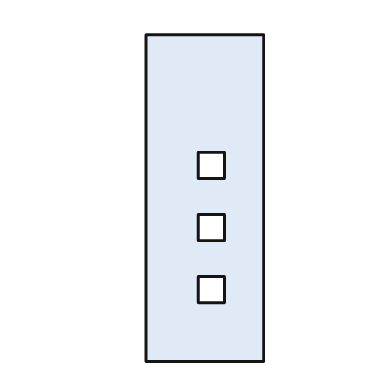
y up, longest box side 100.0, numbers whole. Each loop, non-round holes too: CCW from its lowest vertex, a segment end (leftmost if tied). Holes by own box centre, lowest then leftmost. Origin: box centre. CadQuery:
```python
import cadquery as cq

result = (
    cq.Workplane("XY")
    .moveTo(-18.0, -50.0)
    .lineTo(18.0, -50.0)
    .lineTo(18.0, 50.0)
    .lineTo(-18.0, 50.0)
    .close()
    .moveTo(-2.0, -32.0)
    .lineTo(6.0, -32.0)
    .lineTo(6.0, -24.0)
    .lineTo(-2.0, -24.0)
    .close()
    .moveTo(-2.0, -13.0)
    .lineTo(6.0, -13.0)
    .lineTo(6.0, -5.0)
    .lineTo(-2.0, -5.0)
    .close()
    .moveTo(-2.0, 6.0)
    .lineTo(6.0, 6.0)
    .lineTo(6.0, 14.0)
    .lineTo(-2.0, 14.0)
    .close()
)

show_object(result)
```